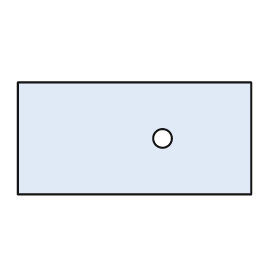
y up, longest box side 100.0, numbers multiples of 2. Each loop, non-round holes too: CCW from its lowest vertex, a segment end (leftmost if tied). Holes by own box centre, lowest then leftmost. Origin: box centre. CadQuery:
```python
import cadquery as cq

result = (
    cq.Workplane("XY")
    .moveTo(-50.0, -24.0)
    .lineTo(50.0, -24.0)
    .lineTo(50.0, 24.0)
    .lineTo(-50.0, 24.0)
    .close()
    .moveTo(12.0, 0.0)
    .circle(4.0)
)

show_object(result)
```